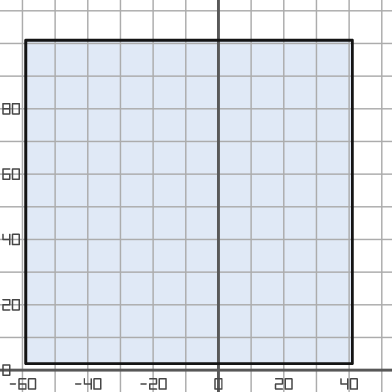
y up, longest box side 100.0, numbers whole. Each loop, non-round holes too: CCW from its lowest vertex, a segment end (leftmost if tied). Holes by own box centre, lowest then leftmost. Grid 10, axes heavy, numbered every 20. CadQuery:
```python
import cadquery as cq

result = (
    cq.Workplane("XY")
    .moveTo(-59.0, 2.0)
    .lineTo(41.0, 2.0)
    .lineTo(41.0, 101.0)
    .lineTo(-59.0, 101.0)
    .close()
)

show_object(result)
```